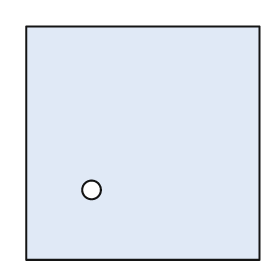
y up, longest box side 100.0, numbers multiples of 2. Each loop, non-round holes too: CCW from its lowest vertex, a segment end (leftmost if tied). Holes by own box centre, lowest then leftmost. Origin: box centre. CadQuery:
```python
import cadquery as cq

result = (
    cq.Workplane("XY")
    .moveTo(-50.0, -50.0)
    .lineTo(50.0, -50.0)
    .lineTo(50.0, 50.0)
    .lineTo(-50.0, 50.0)
    .close()
    .moveTo(-22.0, -20.0)
    .circle(4.0)
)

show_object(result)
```